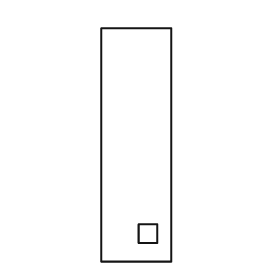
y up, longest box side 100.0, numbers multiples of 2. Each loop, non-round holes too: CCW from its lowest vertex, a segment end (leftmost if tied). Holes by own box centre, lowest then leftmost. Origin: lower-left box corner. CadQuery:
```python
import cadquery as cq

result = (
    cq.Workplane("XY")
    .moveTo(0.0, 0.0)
    .lineTo(30.0, 0.0)
    .lineTo(30.0, 100.0)
    .lineTo(0.0, 100.0)
    .close()
    .moveTo(16.0, 8.0)
    .lineTo(24.0, 8.0)
    .lineTo(24.0, 16.0)
    .lineTo(16.0, 16.0)
    .close()
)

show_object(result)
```